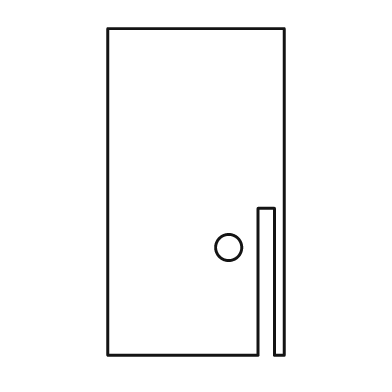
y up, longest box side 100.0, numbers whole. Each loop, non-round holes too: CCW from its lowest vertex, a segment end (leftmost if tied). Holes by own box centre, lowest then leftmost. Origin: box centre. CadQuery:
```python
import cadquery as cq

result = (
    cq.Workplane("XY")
    .moveTo(-27.0, -50.0)
    .lineTo(19.0, -50.0)
    .lineTo(19.0, -5.0)
    .lineTo(24.0, -5.0)
    .lineTo(24.0, -50.0)
    .lineTo(27.0, -50.0)
    .lineTo(27.0, 50.0)
    .lineTo(-27.0, 50.0)
    .close()
    .moveTo(10.0, -17.0)
    .circle(4.0)
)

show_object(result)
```